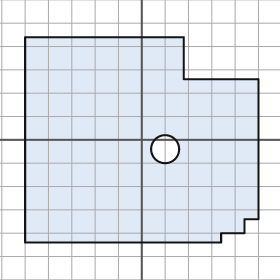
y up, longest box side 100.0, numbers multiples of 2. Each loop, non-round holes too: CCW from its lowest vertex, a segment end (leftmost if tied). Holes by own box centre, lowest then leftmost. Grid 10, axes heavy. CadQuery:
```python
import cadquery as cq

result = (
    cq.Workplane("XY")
    .moveTo(-50.0, -44.0)
    .lineTo(34.0, -44.0)
    .lineTo(34.0, -40.0)
    .lineTo(44.0, -40.0)
    .lineTo(44.0, -34.0)
    .lineTo(50.0, -34.0)
    .lineTo(50.0, 26.0)
    .lineTo(18.0, 26.0)
    .lineTo(18.0, 44.0)
    .lineTo(-50.0, 44.0)
    .close()
    .moveTo(10.0, -4.0)
    .circle(6.0)
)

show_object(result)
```